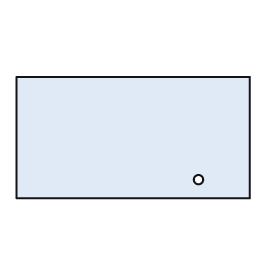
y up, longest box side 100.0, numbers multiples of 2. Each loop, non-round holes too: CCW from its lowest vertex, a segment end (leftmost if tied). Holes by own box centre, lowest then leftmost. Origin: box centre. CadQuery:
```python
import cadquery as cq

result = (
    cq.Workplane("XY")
    .moveTo(-50.0, -26.0)
    .lineTo(50.0, -26.0)
    .lineTo(50.0, 26.0)
    .lineTo(-50.0, 26.0)
    .close()
    .moveTo(28.0, -18.0)
    .circle(2.0)
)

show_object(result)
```